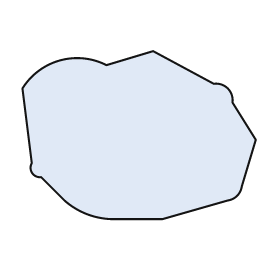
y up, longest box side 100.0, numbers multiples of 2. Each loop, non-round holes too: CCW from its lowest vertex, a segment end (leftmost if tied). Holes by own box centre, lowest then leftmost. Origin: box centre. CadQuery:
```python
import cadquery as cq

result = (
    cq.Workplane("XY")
    .moveTo(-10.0, -36.0)
    .lineTo(10.0, -36.0)
    .lineTo(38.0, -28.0)
    .threePointArc((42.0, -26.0), (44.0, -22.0))
    .lineTo(50.0, -2.0)
    .lineTo(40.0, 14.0)
    .threePointArc((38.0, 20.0), (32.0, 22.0))
    .lineTo(6.0, 36.0)
    .lineTo(-14.0, 30.0)
    .threePointArc((-34.0, 32.0), (-50.0, 20.0))
    .lineTo(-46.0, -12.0)
    .threePointArc((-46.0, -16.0), (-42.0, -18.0))
    .lineTo(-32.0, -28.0)
    .threePointArc((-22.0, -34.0), (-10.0, -36.0))
    .close()
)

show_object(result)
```